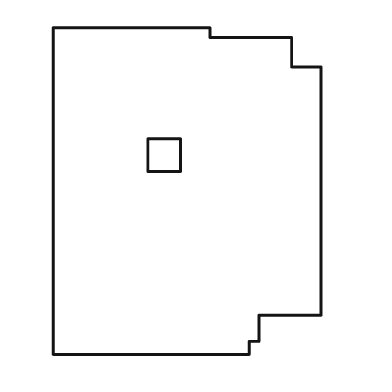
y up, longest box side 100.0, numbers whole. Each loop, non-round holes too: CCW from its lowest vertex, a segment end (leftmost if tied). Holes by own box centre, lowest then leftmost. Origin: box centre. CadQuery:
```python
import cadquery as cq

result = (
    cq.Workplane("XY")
    .moveTo(-41.0, -50.0)
    .lineTo(19.0, -50.0)
    .lineTo(19.0, -46.0)
    .lineTo(22.0, -46.0)
    .lineTo(22.0, -38.0)
    .lineTo(41.0, -38.0)
    .lineTo(41.0, 38.0)
    .lineTo(32.0, 38.0)
    .lineTo(32.0, 47.0)
    .lineTo(7.0, 47.0)
    .lineTo(7.0, 50.0)
    .lineTo(-41.0, 50.0)
    .close()
    .moveTo(-12.0, 6.0)
    .lineTo(-2.0, 6.0)
    .lineTo(-2.0, 16.0)
    .lineTo(-12.0, 16.0)
    .close()
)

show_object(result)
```